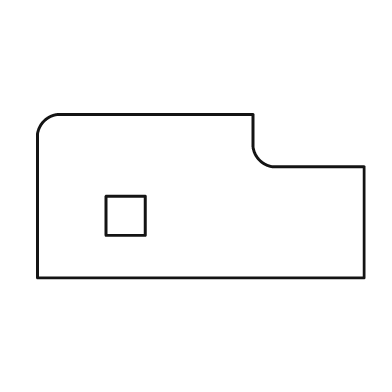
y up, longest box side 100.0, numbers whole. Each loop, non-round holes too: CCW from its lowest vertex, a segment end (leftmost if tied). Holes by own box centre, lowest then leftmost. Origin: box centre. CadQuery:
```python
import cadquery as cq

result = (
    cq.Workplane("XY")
    .moveTo(-50.0, -25.0)
    .lineTo(50.0, -25.0)
    .lineTo(50.0, 9.0)
    .lineTo(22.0, 9.0)
    .threePointArc((18.0, 11.0), (16.0, 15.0))
    .lineTo(16.0, 25.0)
    .lineTo(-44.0, 25.0)
    .threePointArc((-48.0, 23.0), (-50.0, 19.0))
    .close()
    .moveTo(-29.0, -12.0)
    .lineTo(-17.0, -12.0)
    .lineTo(-17.0, 0.0)
    .lineTo(-29.0, 0.0)
    .close()
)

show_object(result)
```